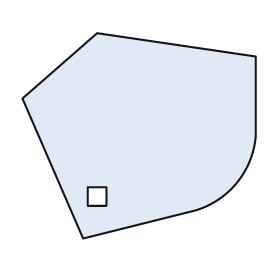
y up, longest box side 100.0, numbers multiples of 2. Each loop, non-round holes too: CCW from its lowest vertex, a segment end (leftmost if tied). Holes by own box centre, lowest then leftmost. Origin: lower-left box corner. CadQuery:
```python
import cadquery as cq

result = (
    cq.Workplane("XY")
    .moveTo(26.0, 0.0)
    .lineTo(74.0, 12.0)
    .threePointArc((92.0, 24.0), (100.0, 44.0))
    .lineTo(100.0, 78.0)
    .lineTo(32.0, 88.0)
    .lineTo(0.0, 60.0)
    .close()
    .moveTo(28.0, 14.0)
    .lineTo(36.0, 14.0)
    .lineTo(36.0, 22.0)
    .lineTo(28.0, 22.0)
    .close()
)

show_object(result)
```